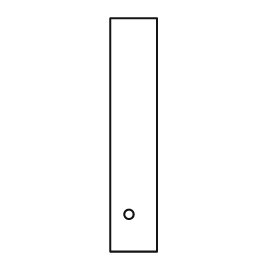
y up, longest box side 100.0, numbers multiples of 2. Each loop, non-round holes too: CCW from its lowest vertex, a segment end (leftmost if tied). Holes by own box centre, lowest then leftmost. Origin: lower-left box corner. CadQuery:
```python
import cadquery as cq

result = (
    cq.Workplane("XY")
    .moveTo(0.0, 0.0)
    .lineTo(20.0, 0.0)
    .lineTo(20.0, 100.0)
    .lineTo(0.0, 100.0)
    .close()
    .moveTo(8.0, 16.0)
    .circle(2.0)
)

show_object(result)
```